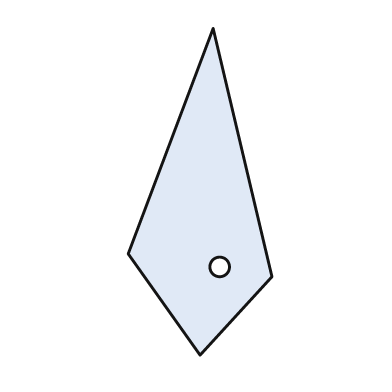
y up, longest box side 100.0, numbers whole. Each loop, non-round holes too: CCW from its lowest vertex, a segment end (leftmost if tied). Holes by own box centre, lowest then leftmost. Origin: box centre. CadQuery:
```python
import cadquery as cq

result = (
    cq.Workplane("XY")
    .moveTo(0.0, -50.0)
    .lineTo(22.0, -26.0)
    .lineTo(4.0, 50.0)
    .lineTo(-22.0, -19.0)
    .close()
    .moveTo(6.0, -23.0)
    .circle(3.0)
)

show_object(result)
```